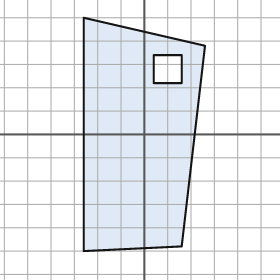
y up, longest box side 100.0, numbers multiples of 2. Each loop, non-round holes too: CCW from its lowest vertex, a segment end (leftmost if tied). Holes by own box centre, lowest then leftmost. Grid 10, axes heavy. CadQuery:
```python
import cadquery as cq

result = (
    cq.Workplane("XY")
    .moveTo(-26.0, -50.0)
    .lineTo(16.0, -48.0)
    .lineTo(26.0, 38.0)
    .lineTo(-26.0, 50.0)
    .close()
    .moveTo(4.0, 22.0)
    .lineTo(16.0, 22.0)
    .lineTo(16.0, 34.0)
    .lineTo(4.0, 34.0)
    .close()
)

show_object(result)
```